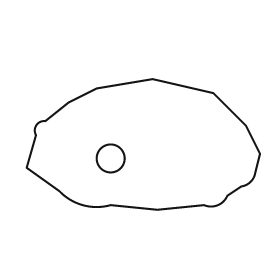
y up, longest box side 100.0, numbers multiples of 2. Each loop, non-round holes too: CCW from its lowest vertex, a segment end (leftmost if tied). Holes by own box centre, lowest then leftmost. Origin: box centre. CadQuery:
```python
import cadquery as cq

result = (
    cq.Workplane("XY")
    .moveTo(6.0, -28.0)
    .lineTo(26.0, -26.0)
    .threePointArc((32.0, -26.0), (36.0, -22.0))
    .lineTo(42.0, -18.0)
    .threePointArc((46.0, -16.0), (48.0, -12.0))
    .lineTo(50.0, -4.0)
    .lineTo(44.0, 8.0)
    .lineTo(30.0, 22.0)
    .lineTo(4.0, 28.0)
    .lineTo(-20.0, 24.0)
    .lineTo(-32.0, 18.0)
    .lineTo(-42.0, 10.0)
    .threePointArc((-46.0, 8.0), (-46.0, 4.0))
    .lineTo(-50.0, -10.0)
    .lineTo(-36.0, -20.0)
    .threePointArc((-26.0, -26.0), (-14.0, -26.0))
    .close()
    .moveTo(-14.0, -6.0)
    .circle(6.0)
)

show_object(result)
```